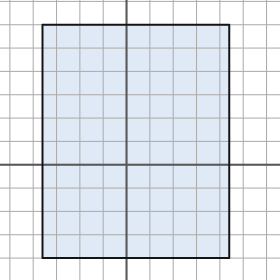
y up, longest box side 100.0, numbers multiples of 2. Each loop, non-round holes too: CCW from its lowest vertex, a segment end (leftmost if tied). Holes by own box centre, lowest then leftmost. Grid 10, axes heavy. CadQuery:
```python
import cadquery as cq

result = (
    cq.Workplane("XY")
    .moveTo(-36.0, -40.0)
    .lineTo(44.0, -40.0)
    .lineTo(44.0, 60.0)
    .lineTo(-36.0, 60.0)
    .close()
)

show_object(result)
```